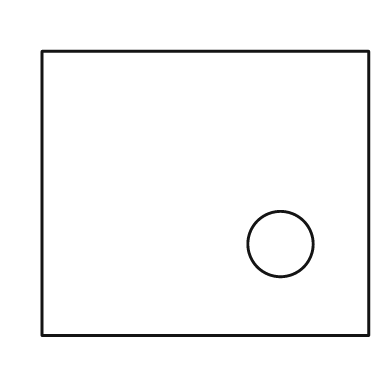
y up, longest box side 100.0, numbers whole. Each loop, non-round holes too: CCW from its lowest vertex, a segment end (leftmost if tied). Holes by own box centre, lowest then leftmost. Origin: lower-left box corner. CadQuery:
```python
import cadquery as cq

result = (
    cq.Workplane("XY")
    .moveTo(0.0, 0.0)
    .lineTo(100.0, 0.0)
    .lineTo(100.0, 87.0)
    .lineTo(0.0, 87.0)
    .close()
    .moveTo(73.0, 28.0)
    .circle(10.0)
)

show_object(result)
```